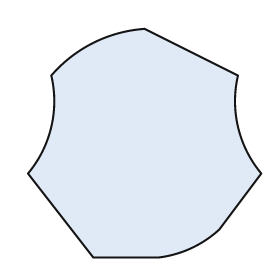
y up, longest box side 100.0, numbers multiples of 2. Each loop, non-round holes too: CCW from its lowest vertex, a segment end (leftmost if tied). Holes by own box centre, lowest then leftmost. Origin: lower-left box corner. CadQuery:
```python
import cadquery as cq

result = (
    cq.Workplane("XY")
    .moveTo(28.0, 0.0)
    .lineTo(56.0, 0.0)
    .threePointArc((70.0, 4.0), (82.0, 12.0))
    .lineTo(100.0, 36.0)
    .threePointArc((90.0, 56.0), (90.0, 78.0))
    .lineTo(50.0, 98.0)
    .threePointArc((28.0, 92.0), (10.0, 78.0))
    .threePointArc((10.0, 56.0), (0.0, 36.0))
    .close()
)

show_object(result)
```